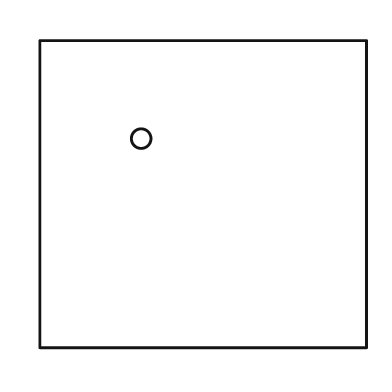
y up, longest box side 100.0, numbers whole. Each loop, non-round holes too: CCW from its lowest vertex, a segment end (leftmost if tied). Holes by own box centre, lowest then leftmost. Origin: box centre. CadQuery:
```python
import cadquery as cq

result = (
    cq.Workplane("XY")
    .moveTo(-50.0, -47.0)
    .lineTo(50.0, -47.0)
    .lineTo(50.0, 47.0)
    .lineTo(-50.0, 47.0)
    .close()
    .moveTo(-19.0, 17.0)
    .circle(3.0)
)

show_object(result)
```